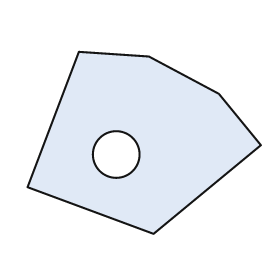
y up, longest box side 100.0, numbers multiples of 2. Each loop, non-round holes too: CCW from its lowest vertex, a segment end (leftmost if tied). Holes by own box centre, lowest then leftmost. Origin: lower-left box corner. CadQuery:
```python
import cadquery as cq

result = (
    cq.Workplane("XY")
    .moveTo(54.0, 0.0)
    .lineTo(100.0, 38.0)
    .lineTo(82.0, 60.0)
    .lineTo(52.0, 76.0)
    .lineTo(22.0, 78.0)
    .lineTo(0.0, 20.0)
    .close()
    .moveTo(38.0, 34.0)
    .circle(10.0)
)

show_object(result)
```